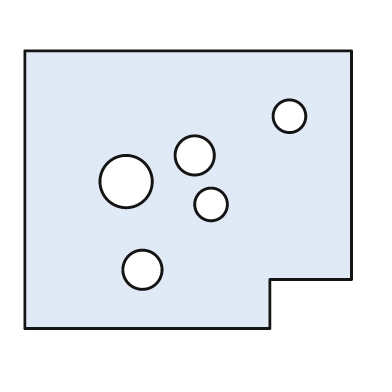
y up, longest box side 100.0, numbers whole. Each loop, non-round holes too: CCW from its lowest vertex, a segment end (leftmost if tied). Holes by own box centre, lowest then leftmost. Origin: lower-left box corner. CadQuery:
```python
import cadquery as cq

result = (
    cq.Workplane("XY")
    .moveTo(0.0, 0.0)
    .lineTo(75.0, 0.0)
    .lineTo(75.0, 15.0)
    .lineTo(100.0, 15.0)
    .lineTo(100.0, 85.0)
    .lineTo(0.0, 85.0)
    .close()
    .moveTo(36.0, 18.0)
    .circle(6.0)
    .moveTo(57.0, 38.0)
    .circle(5.0)
    .moveTo(31.0, 45.0)
    .circle(8.0)
    .moveTo(52.0, 53.0)
    .circle(6.0)
    .moveTo(81.0, 65.0)
    .circle(5.0)
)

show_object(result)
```